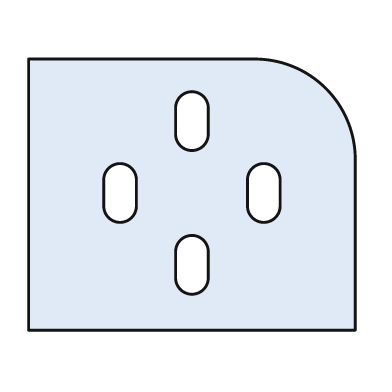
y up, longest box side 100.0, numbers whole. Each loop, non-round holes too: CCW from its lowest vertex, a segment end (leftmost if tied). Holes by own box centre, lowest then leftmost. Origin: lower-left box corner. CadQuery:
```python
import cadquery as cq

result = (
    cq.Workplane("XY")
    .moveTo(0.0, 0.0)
    .lineTo(100.0, 0.0)
    .lineTo(100.0, 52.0)
    .threePointArc((91.0, 74.0), (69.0, 83.0))
    .lineTo(0.0, 83.0)
    .close()
    .moveTo(45.0, 16.0)
    .threePointArc((50.0, 11.0), (55.0, 16.0))
    .lineTo(55.0, 24.0)
    .threePointArc((50.0, 29.0), (45.0, 24.0))
    .close()
    .moveTo(23.0, 38.0)
    .threePointArc((28.0, 33.0), (33.0, 38.0))
    .lineTo(33.0, 46.0)
    .threePointArc((28.0, 51.0), (23.0, 46.0))
    .close()
    .moveTo(67.0, 38.0)
    .threePointArc((72.0, 33.0), (77.0, 38.0))
    .lineTo(77.0, 46.0)
    .threePointArc((72.0, 51.0), (67.0, 46.0))
    .close()
    .moveTo(45.0, 60.0)
    .threePointArc((50.0, 55.0), (55.0, 60.0))
    .lineTo(55.0, 68.0)
    .threePointArc((50.0, 73.0), (45.0, 68.0))
    .close()
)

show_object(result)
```